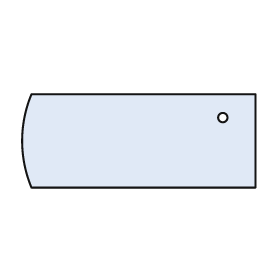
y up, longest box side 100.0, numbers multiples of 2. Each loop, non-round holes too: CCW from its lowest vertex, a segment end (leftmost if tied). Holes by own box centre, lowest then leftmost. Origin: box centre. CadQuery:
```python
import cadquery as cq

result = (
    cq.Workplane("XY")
    .moveTo(-46.0, -20.0)
    .lineTo(50.0, -20.0)
    .lineTo(50.0, 20.0)
    .lineTo(-46.0, 20.0)
    .threePointArc((-50.0, 0.0), (-46.0, -20.0))
    .close()
    .moveTo(36.0, 10.0)
    .circle(2.0)
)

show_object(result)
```